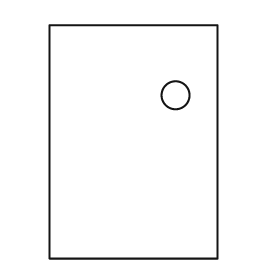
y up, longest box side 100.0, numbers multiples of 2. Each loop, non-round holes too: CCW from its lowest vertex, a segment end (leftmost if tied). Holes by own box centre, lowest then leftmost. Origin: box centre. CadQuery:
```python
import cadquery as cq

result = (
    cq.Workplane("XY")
    .moveTo(-36.0, -50.0)
    .lineTo(36.0, -50.0)
    .lineTo(36.0, 50.0)
    .lineTo(-36.0, 50.0)
    .close()
    .moveTo(18.0, 20.0)
    .circle(6.0)
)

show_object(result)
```